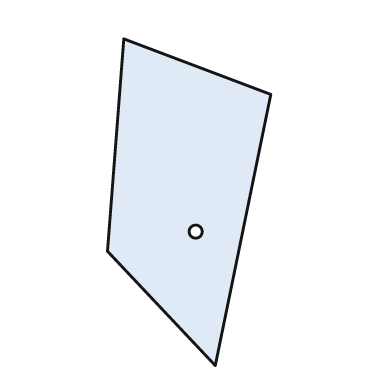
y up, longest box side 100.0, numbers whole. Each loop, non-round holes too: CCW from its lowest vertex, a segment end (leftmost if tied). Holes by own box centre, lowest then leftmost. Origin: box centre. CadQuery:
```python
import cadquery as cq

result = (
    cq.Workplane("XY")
    .moveTo(8.0, -50.0)
    .lineTo(25.0, 33.0)
    .lineTo(-20.0, 50.0)
    .lineTo(-25.0, -15.0)
    .close()
    .moveTo(2.0, -9.0)
    .circle(2.0)
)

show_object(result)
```